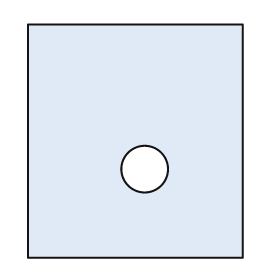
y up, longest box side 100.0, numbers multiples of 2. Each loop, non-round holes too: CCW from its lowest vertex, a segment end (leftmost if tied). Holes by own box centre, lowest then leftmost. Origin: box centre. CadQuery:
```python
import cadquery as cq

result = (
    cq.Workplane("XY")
    .moveTo(-46.0, -50.0)
    .lineTo(46.0, -50.0)
    .lineTo(46.0, 50.0)
    .lineTo(-46.0, 50.0)
    .close()
    .moveTo(4.0, -12.0)
    .circle(10.0)
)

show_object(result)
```